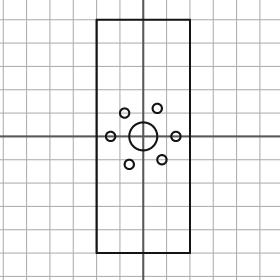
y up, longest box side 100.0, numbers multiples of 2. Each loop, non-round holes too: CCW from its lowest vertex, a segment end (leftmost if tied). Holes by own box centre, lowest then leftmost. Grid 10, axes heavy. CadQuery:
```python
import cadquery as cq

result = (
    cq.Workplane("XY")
    .moveTo(-20.0, -50.0)
    .lineTo(20.0, -50.0)
    .lineTo(20.0, 50.0)
    .lineTo(-20.0, 50.0)
    .close()
    .moveTo(-6.0, -12.0)
    .circle(2.0)
    .moveTo(8.0, -10.0)
    .circle(2.0)
    .moveTo(-14.0, 0.0)
    .circle(2.0)
    .moveTo(0.0, 0.0)
    .circle(6.0)
    .moveTo(14.0, 0.0)
    .circle(2.0)
    .moveTo(-8.0, 10.0)
    .circle(2.0)
    .moveTo(6.0, 12.0)
    .circle(2.0)
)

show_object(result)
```